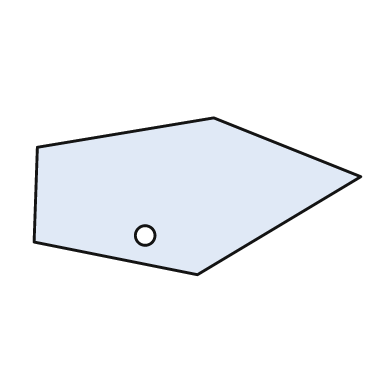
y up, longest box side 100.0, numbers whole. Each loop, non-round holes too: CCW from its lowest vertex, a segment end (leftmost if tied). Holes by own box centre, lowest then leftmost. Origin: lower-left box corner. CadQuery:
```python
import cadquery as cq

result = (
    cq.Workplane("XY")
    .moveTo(50.0, 0.0)
    .lineTo(100.0, 30.0)
    .lineTo(55.0, 48.0)
    .lineTo(1.0, 39.0)
    .lineTo(0.0, 10.0)
    .close()
    .moveTo(34.0, 12.0)
    .circle(3.0)
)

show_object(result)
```